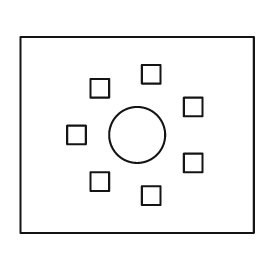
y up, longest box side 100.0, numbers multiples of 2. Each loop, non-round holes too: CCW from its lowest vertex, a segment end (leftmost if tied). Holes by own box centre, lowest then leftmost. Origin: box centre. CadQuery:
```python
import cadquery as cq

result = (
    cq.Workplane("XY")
    .moveTo(-50.0, -42.0)
    .lineTo(50.0, -42.0)
    .lineTo(50.0, 42.0)
    .lineTo(-50.0, 42.0)
    .close()
    .moveTo(2.0, -30.0)
    .lineTo(10.0, -30.0)
    .lineTo(10.0, -22.0)
    .lineTo(2.0, -22.0)
    .close()
    .moveTo(-20.0, -24.0)
    .lineTo(-12.0, -24.0)
    .lineTo(-12.0, -16.0)
    .lineTo(-20.0, -16.0)
    .close()
    .moveTo(20.0, -16.0)
    .lineTo(28.0, -16.0)
    .lineTo(28.0, -8.0)
    .lineTo(20.0, -8.0)
    .close()
    .moveTo(-30.0, -4.0)
    .lineTo(-22.0, -4.0)
    .lineTo(-22.0, 4.0)
    .lineTo(-30.0, 4.0)
    .close()
    .moveTo(0.0, 0.0)
    .circle(12.0)
    .moveTo(20.0, 8.0)
    .lineTo(28.0, 8.0)
    .lineTo(28.0, 16.0)
    .lineTo(20.0, 16.0)
    .close()
    .moveTo(-20.0, 16.0)
    .lineTo(-12.0, 16.0)
    .lineTo(-12.0, 24.0)
    .lineTo(-20.0, 24.0)
    .close()
    .moveTo(2.0, 22.0)
    .lineTo(10.0, 22.0)
    .lineTo(10.0, 30.0)
    .lineTo(2.0, 30.0)
    .close()
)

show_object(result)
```